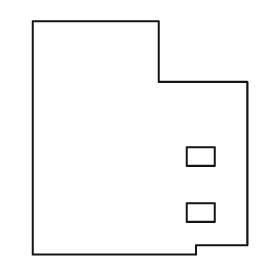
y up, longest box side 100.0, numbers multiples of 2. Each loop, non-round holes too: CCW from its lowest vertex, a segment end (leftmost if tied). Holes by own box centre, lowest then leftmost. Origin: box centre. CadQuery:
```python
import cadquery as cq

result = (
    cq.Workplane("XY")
    .moveTo(-46.0, -50.0)
    .lineTo(24.0, -50.0)
    .lineTo(24.0, -46.0)
    .lineTo(46.0, -46.0)
    .lineTo(46.0, 24.0)
    .lineTo(8.0, 24.0)
    .lineTo(8.0, 50.0)
    .lineTo(-46.0, 50.0)
    .close()
    .moveTo(20.0, -36.0)
    .lineTo(32.0, -36.0)
    .lineTo(32.0, -28.0)
    .lineTo(20.0, -28.0)
    .close()
    .moveTo(20.0, -12.0)
    .lineTo(32.0, -12.0)
    .lineTo(32.0, -4.0)
    .lineTo(20.0, -4.0)
    .close()
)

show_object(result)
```